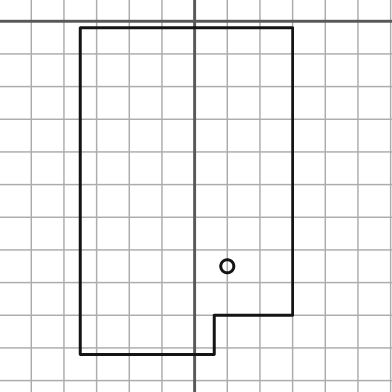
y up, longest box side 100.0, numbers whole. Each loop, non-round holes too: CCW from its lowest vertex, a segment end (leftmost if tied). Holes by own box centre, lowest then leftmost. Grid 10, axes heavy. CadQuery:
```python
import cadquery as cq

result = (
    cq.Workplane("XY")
    .moveTo(-35.0, -102.0)
    .lineTo(6.0, -102.0)
    .lineTo(6.0, -90.0)
    .lineTo(30.0, -90.0)
    .lineTo(30.0, -2.0)
    .lineTo(-35.0, -2.0)
    .close()
    .moveTo(10.0, -75.0)
    .circle(2.0)
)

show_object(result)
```